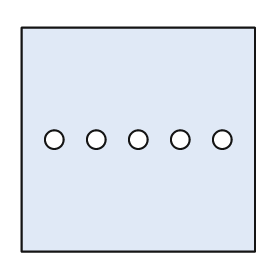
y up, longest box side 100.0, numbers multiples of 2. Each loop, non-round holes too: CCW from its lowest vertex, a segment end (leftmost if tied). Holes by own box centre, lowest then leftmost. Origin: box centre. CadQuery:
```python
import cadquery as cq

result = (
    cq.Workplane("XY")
    .moveTo(-50.0, -48.0)
    .lineTo(50.0, -48.0)
    .lineTo(50.0, 48.0)
    .lineTo(-50.0, 48.0)
    .close()
    .moveTo(-36.0, 0.0)
    .circle(4.0)
    .moveTo(-18.0, 0.0)
    .circle(4.0)
    .moveTo(0.0, 0.0)
    .circle(4.0)
    .moveTo(18.0, 0.0)
    .circle(4.0)
    .moveTo(36.0, 0.0)
    .circle(4.0)
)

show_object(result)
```